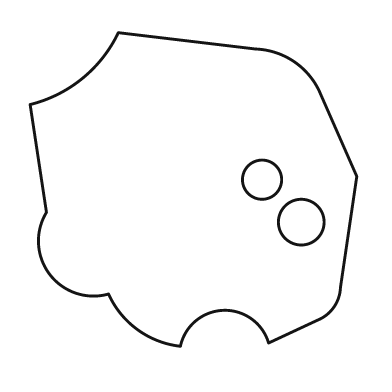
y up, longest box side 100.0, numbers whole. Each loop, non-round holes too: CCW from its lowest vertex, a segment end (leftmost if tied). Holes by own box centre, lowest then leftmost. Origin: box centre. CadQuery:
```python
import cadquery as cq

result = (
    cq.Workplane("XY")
    .moveTo(-4.0, -48.0)
    .threePointArc((9.0, -37.0), (23.0, -47.0))
    .lineTo(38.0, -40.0)
    .threePointArc((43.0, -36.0), (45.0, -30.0))
    .lineTo(50.0, 4.0)
    .lineTo(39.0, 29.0)
    .threePointArc((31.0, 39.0), (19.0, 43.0))
    .lineTo(-23.0, 48.0)
    .threePointArc((-34.0, 34.0), (-50.0, 26.0))
    .lineTo(-45.0, -7.0)
    .threePointArc((-44.0, -26.0), (-26.0, -32.0))
    .threePointArc((-17.0, -43.0), (-4.0, -48.0))
    .close()
    .moveTo(33.0, -10.0)
    .circle(7.0)
    .moveTo(21.0, 3.0)
    .circle(6.0)
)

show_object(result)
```